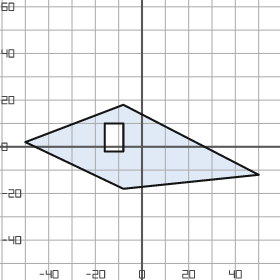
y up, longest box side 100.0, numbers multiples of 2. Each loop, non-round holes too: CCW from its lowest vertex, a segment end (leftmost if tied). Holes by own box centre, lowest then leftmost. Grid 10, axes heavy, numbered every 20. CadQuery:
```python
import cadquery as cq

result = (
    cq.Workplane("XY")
    .moveTo(-8.0, -18.0)
    .lineTo(50.0, -12.0)
    .lineTo(-8.0, 18.0)
    .lineTo(-50.0, 2.0)
    .close()
    .moveTo(-16.0, -2.0)
    .lineTo(-8.0, -2.0)
    .lineTo(-8.0, 10.0)
    .lineTo(-16.0, 10.0)
    .close()
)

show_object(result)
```